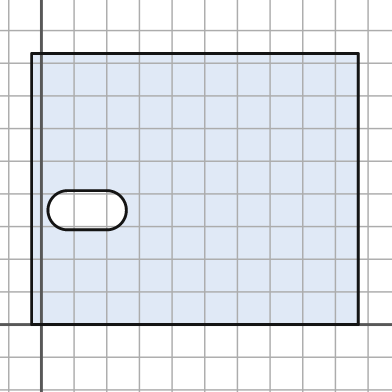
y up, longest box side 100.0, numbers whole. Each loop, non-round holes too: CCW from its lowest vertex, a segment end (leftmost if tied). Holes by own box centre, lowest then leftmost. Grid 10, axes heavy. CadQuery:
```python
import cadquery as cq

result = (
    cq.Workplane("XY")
    .moveTo(-3.0, 0.0)
    .lineTo(97.0, 0.0)
    .lineTo(97.0, 83.0)
    .lineTo(-3.0, 83.0)
    .close()
    .moveTo(8.0, 29.0)
    .lineTo(20.0, 29.0)
    .threePointArc((26.0, 35.0), (20.0, 41.0))
    .lineTo(8.0, 41.0)
    .threePointArc((2.0, 35.0), (8.0, 29.0))
    .close()
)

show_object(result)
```